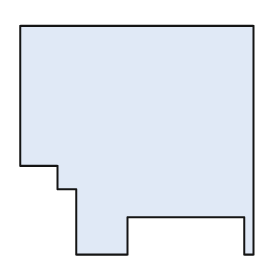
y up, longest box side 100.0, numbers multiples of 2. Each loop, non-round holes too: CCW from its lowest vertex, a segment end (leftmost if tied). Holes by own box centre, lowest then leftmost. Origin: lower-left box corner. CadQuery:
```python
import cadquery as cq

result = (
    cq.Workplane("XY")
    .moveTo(24.0, 0.0)
    .lineTo(46.0, 0.0)
    .lineTo(46.0, 16.0)
    .lineTo(96.0, 16.0)
    .lineTo(96.0, 0.0)
    .lineTo(100.0, 0.0)
    .lineTo(100.0, 98.0)
    .lineTo(0.0, 98.0)
    .lineTo(0.0, 38.0)
    .lineTo(16.0, 38.0)
    .lineTo(16.0, 28.0)
    .lineTo(24.0, 28.0)
    .close()
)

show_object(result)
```